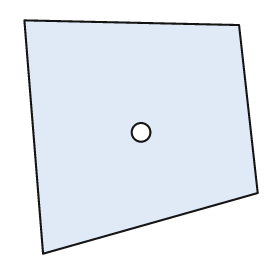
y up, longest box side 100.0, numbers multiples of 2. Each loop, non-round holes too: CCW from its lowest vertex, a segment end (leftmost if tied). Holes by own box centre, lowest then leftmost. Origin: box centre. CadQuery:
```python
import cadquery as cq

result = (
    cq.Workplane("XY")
    .moveTo(-42.0, -50.0)
    .lineTo(50.0, -24.0)
    .lineTo(42.0, 48.0)
    .lineTo(-50.0, 50.0)
    .close()
    .moveTo(0.0, 2.0)
    .circle(4.0)
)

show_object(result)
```